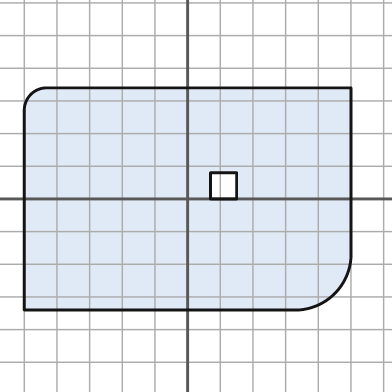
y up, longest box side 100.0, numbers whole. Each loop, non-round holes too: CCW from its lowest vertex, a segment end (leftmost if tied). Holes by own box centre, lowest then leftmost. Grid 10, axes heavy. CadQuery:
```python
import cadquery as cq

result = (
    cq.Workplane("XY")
    .moveTo(-50.0, -34.0)
    .lineTo(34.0, -34.0)
    .threePointArc((45.0, -29.0), (50.0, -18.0))
    .lineTo(50.0, 34.0)
    .lineTo(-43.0, 34.0)
    .threePointArc((-48.0, 32.0), (-50.0, 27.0))
    .close()
    .moveTo(7.0, 0.0)
    .lineTo(15.0, 0.0)
    .lineTo(15.0, 8.0)
    .lineTo(7.0, 8.0)
    .close()
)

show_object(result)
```